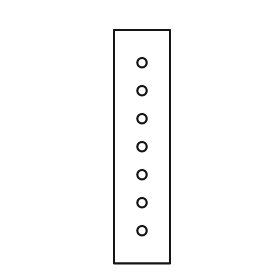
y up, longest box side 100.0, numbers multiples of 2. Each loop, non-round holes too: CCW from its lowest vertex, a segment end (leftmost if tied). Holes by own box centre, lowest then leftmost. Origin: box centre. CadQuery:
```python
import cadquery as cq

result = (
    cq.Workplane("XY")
    .moveTo(-12.0, -50.0)
    .lineTo(12.0, -50.0)
    .lineTo(12.0, 50.0)
    .lineTo(-12.0, 50.0)
    .close()
    .moveTo(0.0, -36.0)
    .circle(2.0)
    .moveTo(0.0, -24.0)
    .circle(2.0)
    .moveTo(0.0, -12.0)
    .circle(2.0)
    .moveTo(0.0, 0.0)
    .circle(2.0)
    .moveTo(0.0, 12.0)
    .circle(2.0)
    .moveTo(0.0, 24.0)
    .circle(2.0)
    .moveTo(0.0, 36.0)
    .circle(2.0)
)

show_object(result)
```